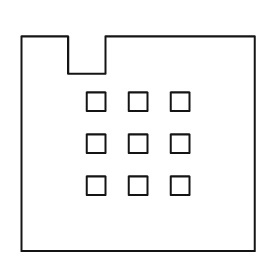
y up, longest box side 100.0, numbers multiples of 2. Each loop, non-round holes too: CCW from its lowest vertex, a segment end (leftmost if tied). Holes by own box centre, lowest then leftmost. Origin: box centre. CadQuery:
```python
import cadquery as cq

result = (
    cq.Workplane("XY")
    .moveTo(-50.0, -46.0)
    .lineTo(50.0, -46.0)
    .lineTo(50.0, 46.0)
    .lineTo(-14.0, 46.0)
    .lineTo(-14.0, 30.0)
    .lineTo(-30.0, 30.0)
    .lineTo(-30.0, 46.0)
    .lineTo(-50.0, 46.0)
    .close()
    .moveTo(-22.0, -22.0)
    .lineTo(-14.0, -22.0)
    .lineTo(-14.0, -14.0)
    .lineTo(-22.0, -14.0)
    .close()
    .moveTo(-4.0, -22.0)
    .lineTo(4.0, -22.0)
    .lineTo(4.0, -14.0)
    .lineTo(-4.0, -14.0)
    .close()
    .moveTo(14.0, -22.0)
    .lineTo(22.0, -22.0)
    .lineTo(22.0, -14.0)
    .lineTo(14.0, -14.0)
    .close()
    .moveTo(-22.0, -4.0)
    .lineTo(-14.0, -4.0)
    .lineTo(-14.0, 4.0)
    .lineTo(-22.0, 4.0)
    .close()
    .moveTo(-4.0, -4.0)
    .lineTo(4.0, -4.0)
    .lineTo(4.0, 4.0)
    .lineTo(-4.0, 4.0)
    .close()
    .moveTo(14.0, -4.0)
    .lineTo(22.0, -4.0)
    .lineTo(22.0, 4.0)
    .lineTo(14.0, 4.0)
    .close()
    .moveTo(-22.0, 14.0)
    .lineTo(-14.0, 14.0)
    .lineTo(-14.0, 22.0)
    .lineTo(-22.0, 22.0)
    .close()
    .moveTo(-4.0, 14.0)
    .lineTo(4.0, 14.0)
    .lineTo(4.0, 22.0)
    .lineTo(-4.0, 22.0)
    .close()
    .moveTo(14.0, 14.0)
    .lineTo(22.0, 14.0)
    .lineTo(22.0, 22.0)
    .lineTo(14.0, 22.0)
    .close()
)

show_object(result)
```